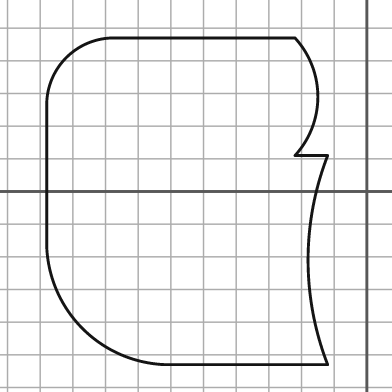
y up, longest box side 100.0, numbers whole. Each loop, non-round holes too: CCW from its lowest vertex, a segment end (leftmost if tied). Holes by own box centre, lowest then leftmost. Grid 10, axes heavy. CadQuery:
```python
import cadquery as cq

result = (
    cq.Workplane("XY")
    .moveTo(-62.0, -53.0)
    .lineTo(-12.0, -53.0)
    .threePointArc((-18.0, -21.0), (-12.0, 11.0))
    .lineTo(-22.0, 11.0)
    .threePointArc((-15.0, 29.0), (-22.0, 47.0))
    .lineTo(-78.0, 47.0)
    .threePointArc((-92.0, 41.0), (-98.0, 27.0))
    .lineTo(-98.0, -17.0)
    .threePointArc((-87.0, -42.0), (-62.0, -53.0))
    .close()
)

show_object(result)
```